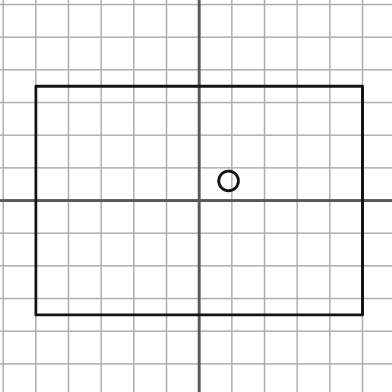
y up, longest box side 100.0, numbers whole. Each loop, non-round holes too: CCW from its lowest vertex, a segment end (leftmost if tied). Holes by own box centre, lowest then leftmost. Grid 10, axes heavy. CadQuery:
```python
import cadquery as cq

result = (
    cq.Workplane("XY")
    .moveTo(-50.0, -35.0)
    .lineTo(50.0, -35.0)
    .lineTo(50.0, 35.0)
    .lineTo(-50.0, 35.0)
    .close()
    .moveTo(9.0, 6.0)
    .circle(3.0)
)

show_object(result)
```